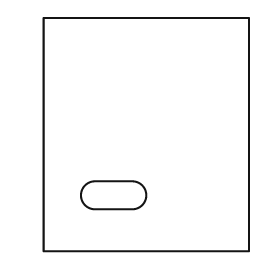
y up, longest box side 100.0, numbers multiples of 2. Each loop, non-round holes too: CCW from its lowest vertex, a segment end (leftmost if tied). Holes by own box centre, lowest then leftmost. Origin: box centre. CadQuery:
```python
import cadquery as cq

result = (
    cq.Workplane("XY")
    .moveTo(-44.0, -50.0)
    .lineTo(44.0, -50.0)
    .lineTo(44.0, 50.0)
    .lineTo(-44.0, 50.0)
    .close()
    .moveTo(-22.0, -32.0)
    .lineTo(-6.0, -32.0)
    .threePointArc((0.0, -26.0), (-6.0, -20.0))
    .lineTo(-22.0, -20.0)
    .threePointArc((-28.0, -26.0), (-22.0, -32.0))
    .close()
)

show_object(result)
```